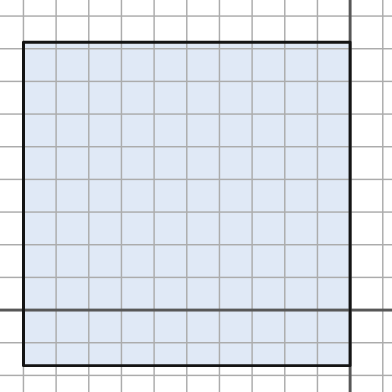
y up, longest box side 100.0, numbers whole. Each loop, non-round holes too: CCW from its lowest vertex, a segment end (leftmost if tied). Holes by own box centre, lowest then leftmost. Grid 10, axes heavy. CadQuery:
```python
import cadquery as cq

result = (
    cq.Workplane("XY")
    .moveTo(-100.0, -17.0)
    .lineTo(0.0, -17.0)
    .lineTo(0.0, 82.0)
    .lineTo(-100.0, 82.0)
    .close()
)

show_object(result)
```